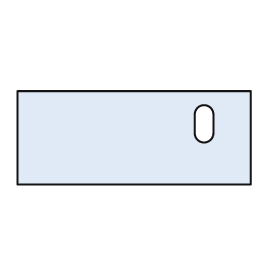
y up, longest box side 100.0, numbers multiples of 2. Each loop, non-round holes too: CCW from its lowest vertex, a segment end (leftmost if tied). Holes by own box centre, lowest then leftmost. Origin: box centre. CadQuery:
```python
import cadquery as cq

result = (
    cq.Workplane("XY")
    .moveTo(-50.0, -20.0)
    .lineTo(50.0, -20.0)
    .lineTo(50.0, 20.0)
    .lineTo(-50.0, 20.0)
    .close()
    .moveTo(26.0, 2.0)
    .threePointArc((30.0, -2.0), (34.0, 2.0))
    .lineTo(34.0, 10.0)
    .threePointArc((30.0, 14.0), (26.0, 10.0))
    .close()
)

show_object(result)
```